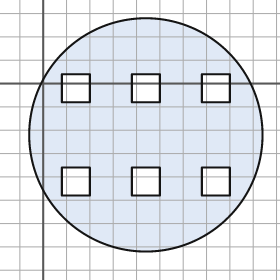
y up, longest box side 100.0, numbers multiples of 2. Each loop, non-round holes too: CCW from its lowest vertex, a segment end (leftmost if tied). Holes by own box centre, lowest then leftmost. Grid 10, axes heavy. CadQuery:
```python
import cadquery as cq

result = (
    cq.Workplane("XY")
    .moveTo(44.0, -22.0)
    .circle(50.0)
    .moveTo(8.0, -48.0)
    .lineTo(20.0, -48.0)
    .lineTo(20.0, -36.0)
    .lineTo(8.0, -36.0)
    .close()
    .moveTo(38.0, -48.0)
    .lineTo(50.0, -48.0)
    .lineTo(50.0, -36.0)
    .lineTo(38.0, -36.0)
    .close()
    .moveTo(68.0, -48.0)
    .lineTo(80.0, -48.0)
    .lineTo(80.0, -36.0)
    .lineTo(68.0, -36.0)
    .close()
    .moveTo(8.0, -8.0)
    .lineTo(20.0, -8.0)
    .lineTo(20.0, 4.0)
    .lineTo(8.0, 4.0)
    .close()
    .moveTo(38.0, -8.0)
    .lineTo(50.0, -8.0)
    .lineTo(50.0, 4.0)
    .lineTo(38.0, 4.0)
    .close()
    .moveTo(68.0, -8.0)
    .lineTo(80.0, -8.0)
    .lineTo(80.0, 4.0)
    .lineTo(68.0, 4.0)
    .close()
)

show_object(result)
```